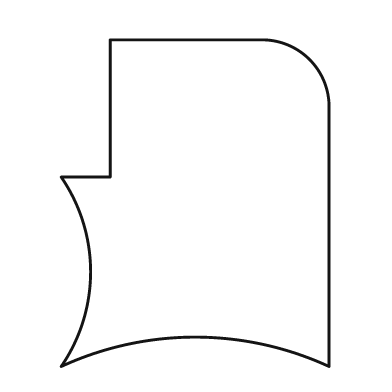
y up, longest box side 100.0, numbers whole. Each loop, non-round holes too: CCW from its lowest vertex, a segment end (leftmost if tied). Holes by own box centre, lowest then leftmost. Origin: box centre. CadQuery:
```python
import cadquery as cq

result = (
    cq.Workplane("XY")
    .moveTo(-41.0, -50.0)
    .threePointArc((0.0, -41.0), (41.0, -50.0))
    .lineTo(41.0, 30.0)
    .threePointArc((35.0, 44.0), (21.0, 50.0))
    .lineTo(-26.0, 50.0)
    .lineTo(-26.0, 8.0)
    .lineTo(-41.0, 8.0)
    .threePointArc((-32.0, -21.0), (-41.0, -50.0))
    .close()
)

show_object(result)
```